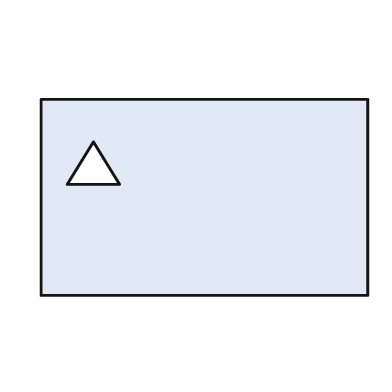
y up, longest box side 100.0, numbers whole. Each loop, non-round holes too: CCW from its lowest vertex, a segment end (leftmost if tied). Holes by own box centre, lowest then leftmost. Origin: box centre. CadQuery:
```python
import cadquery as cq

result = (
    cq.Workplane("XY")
    .moveTo(-50.0, -30.0)
    .lineTo(50.0, -30.0)
    .lineTo(50.0, 30.0)
    .lineTo(-50.0, 30.0)
    .close()
    .moveTo(-42.0, 4.0)
    .lineTo(-26.0, 4.0)
    .lineTo(-34.0, 17.0)
    .close()
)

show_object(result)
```